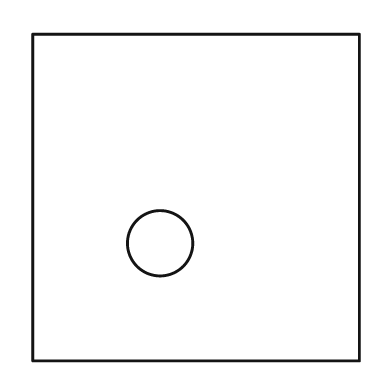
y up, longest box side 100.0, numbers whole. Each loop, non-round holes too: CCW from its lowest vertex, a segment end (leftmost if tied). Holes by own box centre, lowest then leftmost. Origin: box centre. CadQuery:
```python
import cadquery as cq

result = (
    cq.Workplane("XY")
    .moveTo(-50.0, -50.0)
    .lineTo(50.0, -50.0)
    .lineTo(50.0, 50.0)
    .lineTo(-50.0, 50.0)
    .close()
    .moveTo(-11.0, -14.0)
    .circle(10.0)
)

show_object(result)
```